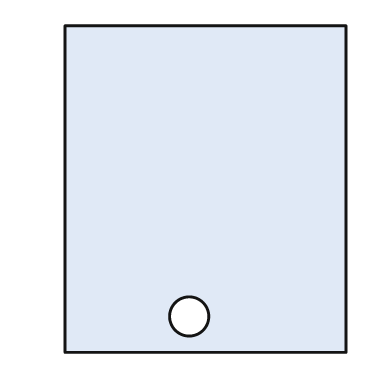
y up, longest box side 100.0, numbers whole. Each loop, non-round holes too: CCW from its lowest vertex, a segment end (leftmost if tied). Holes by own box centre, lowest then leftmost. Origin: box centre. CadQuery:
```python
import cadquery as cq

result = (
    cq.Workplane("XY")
    .moveTo(-43.0, -50.0)
    .lineTo(43.0, -50.0)
    .lineTo(43.0, 50.0)
    .lineTo(-43.0, 50.0)
    .close()
    .moveTo(-5.0, -39.0)
    .circle(6.0)
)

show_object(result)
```